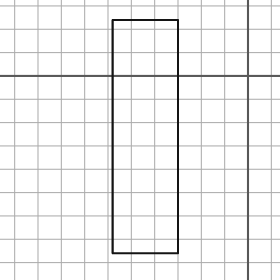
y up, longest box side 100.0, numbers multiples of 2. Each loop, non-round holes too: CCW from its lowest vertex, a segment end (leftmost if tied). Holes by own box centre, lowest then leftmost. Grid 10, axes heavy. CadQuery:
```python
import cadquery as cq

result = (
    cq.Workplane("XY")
    .moveTo(-58.0, -76.0)
    .lineTo(-30.0, -76.0)
    .lineTo(-30.0, 24.0)
    .lineTo(-58.0, 24.0)
    .close()
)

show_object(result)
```